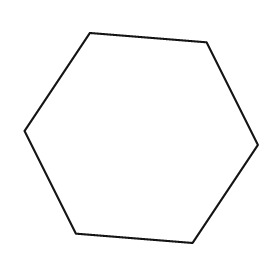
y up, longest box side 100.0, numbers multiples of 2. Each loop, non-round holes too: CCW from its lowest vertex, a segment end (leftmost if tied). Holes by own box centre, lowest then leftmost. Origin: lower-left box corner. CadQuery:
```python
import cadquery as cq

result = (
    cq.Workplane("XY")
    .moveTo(72.0, 0.0)
    .lineTo(100.0, 42.0)
    .lineTo(78.0, 86.0)
    .lineTo(28.0, 90.0)
    .lineTo(0.0, 48.0)
    .lineTo(22.0, 4.0)
    .close()
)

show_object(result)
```